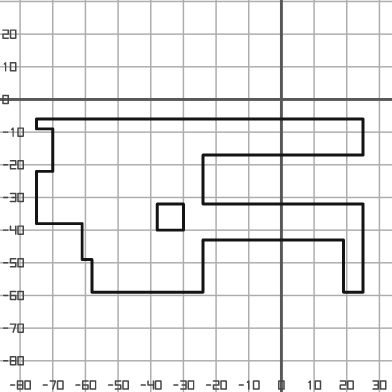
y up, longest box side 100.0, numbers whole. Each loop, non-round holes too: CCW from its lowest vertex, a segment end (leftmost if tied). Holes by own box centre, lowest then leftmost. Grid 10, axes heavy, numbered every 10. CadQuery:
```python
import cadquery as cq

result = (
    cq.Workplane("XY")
    .moveTo(-58.0, -59.0)
    .lineTo(-24.0, -59.0)
    .lineTo(-24.0, -43.0)
    .lineTo(19.0, -43.0)
    .lineTo(19.0, -59.0)
    .lineTo(25.0, -59.0)
    .lineTo(25.0, -32.0)
    .lineTo(-24.0, -32.0)
    .lineTo(-24.0, -17.0)
    .lineTo(25.0, -17.0)
    .lineTo(25.0, -6.0)
    .lineTo(-75.0, -6.0)
    .lineTo(-75.0, -9.0)
    .lineTo(-70.0, -9.0)
    .lineTo(-70.0, -22.0)
    .lineTo(-75.0, -22.0)
    .lineTo(-75.0, -38.0)
    .lineTo(-61.0, -38.0)
    .lineTo(-61.0, -49.0)
    .lineTo(-58.0, -49.0)
    .close()
    .moveTo(-38.0, -40.0)
    .lineTo(-30.0, -40.0)
    .lineTo(-30.0, -32.0)
    .lineTo(-38.0, -32.0)
    .close()
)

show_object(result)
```